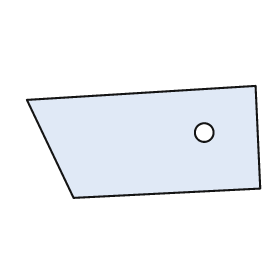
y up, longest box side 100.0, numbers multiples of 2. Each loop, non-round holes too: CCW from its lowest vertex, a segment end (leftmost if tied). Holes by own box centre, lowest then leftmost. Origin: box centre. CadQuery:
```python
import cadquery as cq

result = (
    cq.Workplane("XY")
    .moveTo(-30.0, -24.0)
    .lineTo(50.0, -20.0)
    .lineTo(48.0, 24.0)
    .lineTo(-50.0, 18.0)
    .close()
    .moveTo(26.0, 4.0)
    .circle(4.0)
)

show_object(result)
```